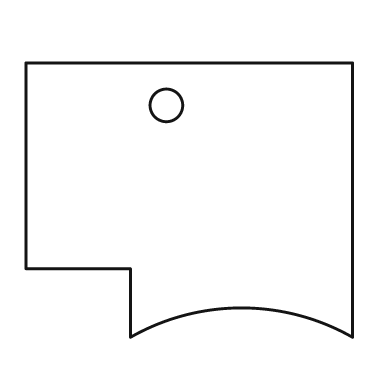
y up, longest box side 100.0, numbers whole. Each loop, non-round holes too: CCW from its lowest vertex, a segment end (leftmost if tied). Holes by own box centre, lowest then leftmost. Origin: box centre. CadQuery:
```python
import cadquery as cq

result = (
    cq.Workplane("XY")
    .moveTo(-18.0, -42.0)
    .threePointArc((16.0, -33.0), (50.0, -42.0))
    .lineTo(50.0, 42.0)
    .lineTo(-50.0, 42.0)
    .lineTo(-50.0, -21.0)
    .lineTo(-18.0, -21.0)
    .close()
    .moveTo(-7.0, 29.0)
    .circle(5.0)
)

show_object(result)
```